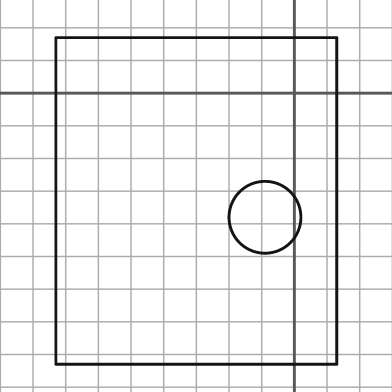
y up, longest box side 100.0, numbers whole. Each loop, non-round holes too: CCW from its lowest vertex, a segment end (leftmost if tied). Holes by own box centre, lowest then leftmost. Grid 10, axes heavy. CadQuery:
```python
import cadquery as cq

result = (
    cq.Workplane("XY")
    .moveTo(-73.0, -83.0)
    .lineTo(13.0, -83.0)
    .lineTo(13.0, 17.0)
    .lineTo(-73.0, 17.0)
    .close()
    .moveTo(-9.0, -38.0)
    .circle(11.0)
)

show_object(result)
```